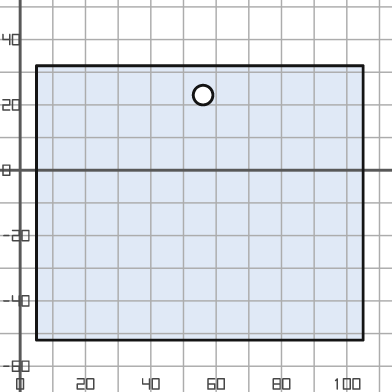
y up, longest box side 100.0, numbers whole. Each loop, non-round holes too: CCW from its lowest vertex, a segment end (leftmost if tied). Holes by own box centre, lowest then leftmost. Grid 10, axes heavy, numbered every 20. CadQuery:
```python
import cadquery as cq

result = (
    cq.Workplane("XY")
    .moveTo(5.0, -52.0)
    .lineTo(105.0, -52.0)
    .lineTo(105.0, 32.0)
    .lineTo(5.0, 32.0)
    .close()
    .moveTo(56.0, 23.0)
    .circle(3.0)
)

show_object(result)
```